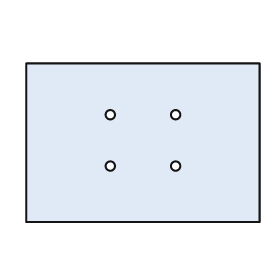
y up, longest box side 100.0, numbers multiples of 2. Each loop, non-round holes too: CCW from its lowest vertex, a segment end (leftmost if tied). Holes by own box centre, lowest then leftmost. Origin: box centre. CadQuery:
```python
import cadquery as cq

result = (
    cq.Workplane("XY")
    .moveTo(-50.0, -34.0)
    .lineTo(50.0, -34.0)
    .lineTo(50.0, 34.0)
    .lineTo(-50.0, 34.0)
    .close()
    .moveTo(-14.0, -10.0)
    .circle(2.0)
    .moveTo(14.0, -10.0)
    .circle(2.0)
    .moveTo(-14.0, 12.0)
    .circle(2.0)
    .moveTo(14.0, 12.0)
    .circle(2.0)
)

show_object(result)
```